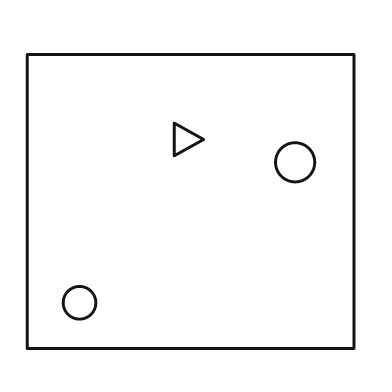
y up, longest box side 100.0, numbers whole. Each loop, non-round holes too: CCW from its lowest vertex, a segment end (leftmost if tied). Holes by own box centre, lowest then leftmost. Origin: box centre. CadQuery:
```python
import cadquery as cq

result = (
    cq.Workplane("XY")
    .moveTo(-50.0, -45.0)
    .lineTo(50.0, -45.0)
    .lineTo(50.0, 45.0)
    .lineTo(-50.0, 45.0)
    .close()
    .moveTo(-34.0, -31.0)
    .circle(5.0)
    .moveTo(32.0, 12.0)
    .circle(6.0)
    .moveTo(-5.0, 14.0)
    .lineTo(4.0, 19.0)
    .lineTo(-5.0, 24.0)
    .close()
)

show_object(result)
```